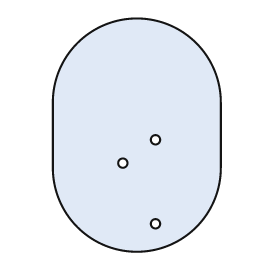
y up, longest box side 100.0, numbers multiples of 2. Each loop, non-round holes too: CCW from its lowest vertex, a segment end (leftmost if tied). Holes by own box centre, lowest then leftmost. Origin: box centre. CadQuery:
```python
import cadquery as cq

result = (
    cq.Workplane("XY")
    .moveTo(-36.0, -14.0)
    .threePointArc((0.0, -50.0), (36.0, -14.0))
    .lineTo(36.0, 14.0)
    .threePointArc((0.0, 50.0), (-36.0, 14.0))
    .close()
    .moveTo(8.0, -38.0)
    .circle(2.0)
    .moveTo(-6.0, -12.0)
    .circle(2.0)
    .moveTo(8.0, -2.0)
    .circle(2.0)
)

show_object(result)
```